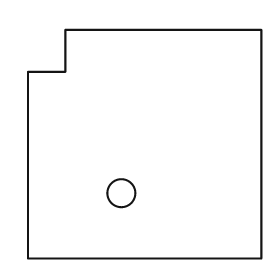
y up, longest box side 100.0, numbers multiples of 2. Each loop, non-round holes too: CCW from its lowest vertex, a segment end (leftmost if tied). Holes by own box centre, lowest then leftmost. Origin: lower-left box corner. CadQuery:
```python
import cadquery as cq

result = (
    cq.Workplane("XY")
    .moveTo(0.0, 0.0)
    .lineTo(100.0, 0.0)
    .lineTo(100.0, 98.0)
    .lineTo(16.0, 98.0)
    .lineTo(16.0, 80.0)
    .lineTo(0.0, 80.0)
    .close()
    .moveTo(40.0, 28.0)
    .circle(6.0)
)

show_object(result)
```